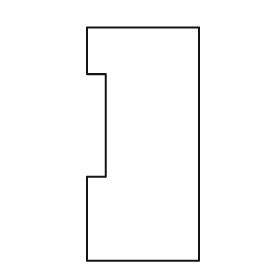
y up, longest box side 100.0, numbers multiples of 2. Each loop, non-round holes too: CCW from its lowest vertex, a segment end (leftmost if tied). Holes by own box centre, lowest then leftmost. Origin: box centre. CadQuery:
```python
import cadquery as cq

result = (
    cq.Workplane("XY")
    .moveTo(-24.0, -50.0)
    .lineTo(24.0, -50.0)
    .lineTo(24.0, 50.0)
    .lineTo(-24.0, 50.0)
    .lineTo(-24.0, 30.0)
    .lineTo(-16.0, 30.0)
    .lineTo(-16.0, -14.0)
    .lineTo(-24.0, -14.0)
    .close()
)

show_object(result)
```